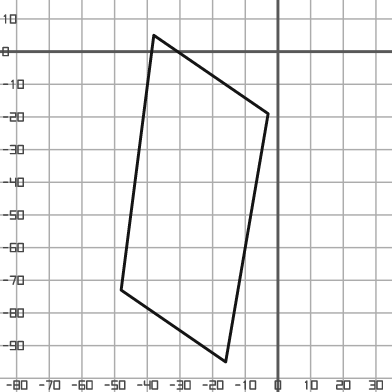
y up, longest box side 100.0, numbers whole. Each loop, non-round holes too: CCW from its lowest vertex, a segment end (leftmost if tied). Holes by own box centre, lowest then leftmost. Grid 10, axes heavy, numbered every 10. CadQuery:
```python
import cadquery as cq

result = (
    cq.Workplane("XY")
    .moveTo(-16.0, -95.0)
    .lineTo(-3.0, -19.0)
    .lineTo(-38.0, 5.0)
    .lineTo(-48.0, -73.0)
    .close()
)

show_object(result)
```